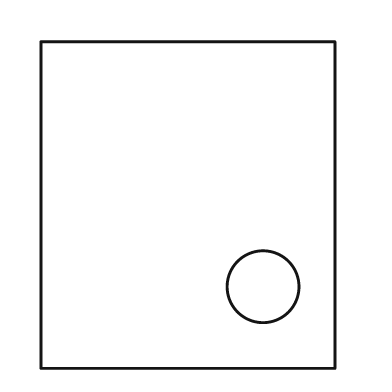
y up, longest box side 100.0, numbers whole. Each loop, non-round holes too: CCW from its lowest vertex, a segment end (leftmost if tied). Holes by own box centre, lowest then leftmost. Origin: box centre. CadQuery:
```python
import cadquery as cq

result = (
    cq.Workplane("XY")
    .moveTo(-45.0, -50.0)
    .lineTo(45.0, -50.0)
    .lineTo(45.0, 50.0)
    .lineTo(-45.0, 50.0)
    .close()
    .moveTo(23.0, -25.0)
    .circle(11.0)
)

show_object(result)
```